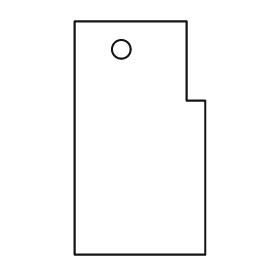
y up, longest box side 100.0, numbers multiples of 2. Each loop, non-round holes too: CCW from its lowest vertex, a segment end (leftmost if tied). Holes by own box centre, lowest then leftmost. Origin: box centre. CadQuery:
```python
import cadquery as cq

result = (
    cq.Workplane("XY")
    .moveTo(-28.0, -50.0)
    .lineTo(28.0, -50.0)
    .lineTo(28.0, 16.0)
    .lineTo(20.0, 16.0)
    .lineTo(20.0, 50.0)
    .lineTo(-28.0, 50.0)
    .close()
    .moveTo(-8.0, 38.0)
    .circle(4.0)
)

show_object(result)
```